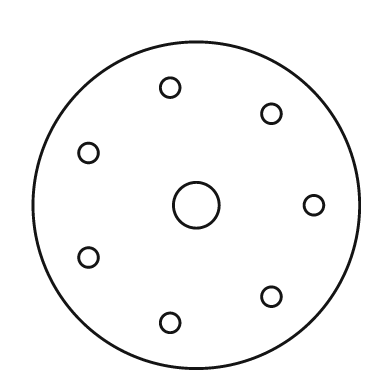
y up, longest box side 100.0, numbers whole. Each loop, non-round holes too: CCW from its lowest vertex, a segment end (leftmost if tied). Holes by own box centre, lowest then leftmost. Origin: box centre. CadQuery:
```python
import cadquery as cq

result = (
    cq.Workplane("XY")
    .moveTo(0.0, 0.0)
    .circle(50.0)
    .moveTo(-8.0, -36.0)
    .circle(3.0)
    .moveTo(23.0, -28.0)
    .circle(3.0)
    .moveTo(-33.0, -16.0)
    .circle(3.0)
    .moveTo(0.0, 0.0)
    .circle(7.0)
    .moveTo(36.0, 0.0)
    .circle(3.0)
    .moveTo(-33.0, 16.0)
    .circle(3.0)
    .moveTo(23.0, 28.0)
    .circle(3.0)
    .moveTo(-8.0, 36.0)
    .circle(3.0)
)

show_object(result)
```